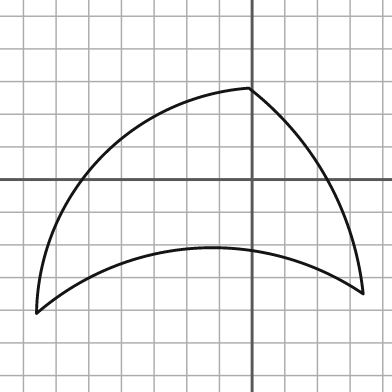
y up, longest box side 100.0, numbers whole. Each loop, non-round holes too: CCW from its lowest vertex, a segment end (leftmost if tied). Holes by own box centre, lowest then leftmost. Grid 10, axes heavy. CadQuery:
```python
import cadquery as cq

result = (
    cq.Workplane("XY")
    .moveTo(-66.0, -41.0)
    .threePointArc((-17.0, -21.0), (34.0, -35.0))
    .threePointArc((23.0, 0.0), (-1.0, 28.0))
    .threePointArc((-47.0, 6.0), (-66.0, -41.0))
    .close()
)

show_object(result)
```